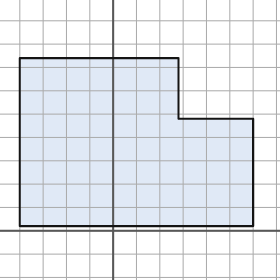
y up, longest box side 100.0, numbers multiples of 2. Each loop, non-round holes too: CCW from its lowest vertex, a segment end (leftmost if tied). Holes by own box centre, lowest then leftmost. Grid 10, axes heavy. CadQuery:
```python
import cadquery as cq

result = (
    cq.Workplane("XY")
    .moveTo(-40.0, 2.0)
    .lineTo(60.0, 2.0)
    .lineTo(60.0, 48.0)
    .lineTo(28.0, 48.0)
    .lineTo(28.0, 74.0)
    .lineTo(-40.0, 74.0)
    .close()
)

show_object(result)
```